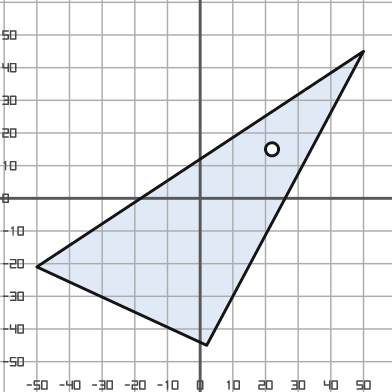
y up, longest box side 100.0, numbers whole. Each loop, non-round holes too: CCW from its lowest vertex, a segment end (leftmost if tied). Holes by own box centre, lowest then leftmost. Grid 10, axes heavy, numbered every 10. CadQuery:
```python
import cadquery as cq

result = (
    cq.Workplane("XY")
    .moveTo(2.0, -45.0)
    .lineTo(50.0, 45.0)
    .lineTo(-50.0, -21.0)
    .close()
    .moveTo(22.0, 15.0)
    .circle(2.0)
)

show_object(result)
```